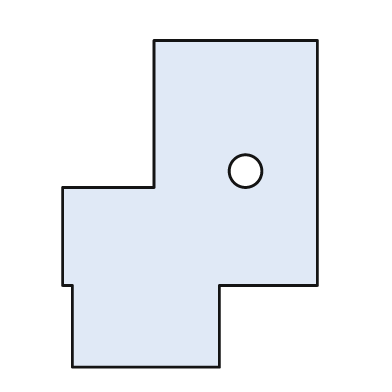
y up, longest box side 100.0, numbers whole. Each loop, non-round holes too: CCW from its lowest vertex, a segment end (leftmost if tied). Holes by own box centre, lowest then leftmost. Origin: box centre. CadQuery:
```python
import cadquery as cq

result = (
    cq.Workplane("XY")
    .moveTo(-36.0, -50.0)
    .lineTo(9.0, -50.0)
    .lineTo(9.0, -25.0)
    .lineTo(39.0, -25.0)
    .lineTo(39.0, 50.0)
    .lineTo(-11.0, 50.0)
    .lineTo(-11.0, 5.0)
    .lineTo(-39.0, 5.0)
    .lineTo(-39.0, -25.0)
    .lineTo(-36.0, -25.0)
    .close()
    .moveTo(17.0, 10.0)
    .circle(5.0)
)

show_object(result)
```